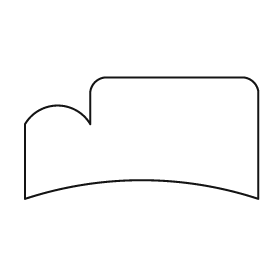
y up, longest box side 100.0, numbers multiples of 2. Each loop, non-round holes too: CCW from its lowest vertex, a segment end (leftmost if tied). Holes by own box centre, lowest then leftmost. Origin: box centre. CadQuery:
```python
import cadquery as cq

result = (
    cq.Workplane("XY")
    .moveTo(-50.0, -26.0)
    .threePointArc((0.0, -18.0), (50.0, -26.0))
    .lineTo(50.0, 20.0)
    .threePointArc((48.0, 24.0), (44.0, 26.0))
    .lineTo(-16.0, 26.0)
    .threePointArc((-20.0, 24.0), (-22.0, 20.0))
    .lineTo(-22.0, 6.0)
    .threePointArc((-36.0, 14.0), (-50.0, 6.0))
    .close()
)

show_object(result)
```